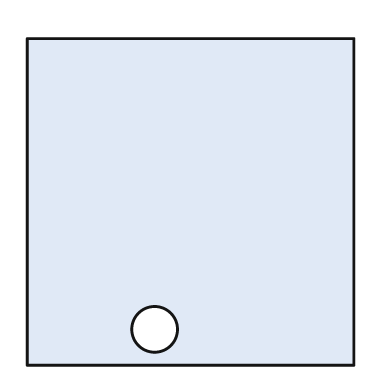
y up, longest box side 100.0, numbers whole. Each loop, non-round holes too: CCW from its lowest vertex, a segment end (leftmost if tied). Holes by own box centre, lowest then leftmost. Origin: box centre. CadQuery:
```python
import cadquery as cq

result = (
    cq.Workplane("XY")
    .moveTo(-50.0, -50.0)
    .lineTo(50.0, -50.0)
    .lineTo(50.0, 50.0)
    .lineTo(-50.0, 50.0)
    .close()
    .moveTo(-11.0, -39.0)
    .circle(7.0)
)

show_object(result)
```